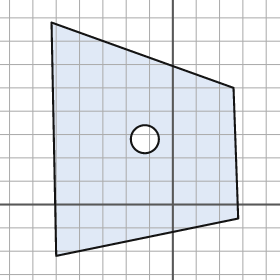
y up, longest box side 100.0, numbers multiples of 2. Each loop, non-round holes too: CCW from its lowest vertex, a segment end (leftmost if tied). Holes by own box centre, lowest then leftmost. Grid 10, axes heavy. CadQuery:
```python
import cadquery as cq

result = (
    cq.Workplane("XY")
    .moveTo(-50.0, -22.0)
    .lineTo(28.0, -6.0)
    .lineTo(26.0, 50.0)
    .lineTo(-52.0, 78.0)
    .close()
    .moveTo(-12.0, 28.0)
    .circle(6.0)
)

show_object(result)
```